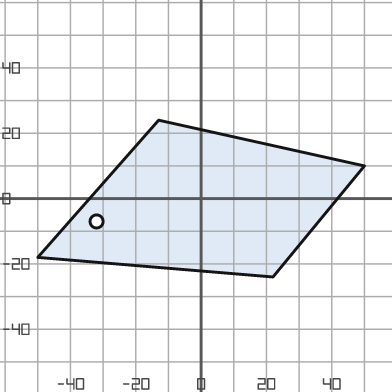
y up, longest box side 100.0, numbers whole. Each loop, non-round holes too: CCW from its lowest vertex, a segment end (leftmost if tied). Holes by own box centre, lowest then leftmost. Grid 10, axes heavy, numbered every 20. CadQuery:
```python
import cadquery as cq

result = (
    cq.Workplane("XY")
    .moveTo(22.0, -24.0)
    .lineTo(50.0, 10.0)
    .lineTo(-13.0, 24.0)
    .lineTo(-50.0, -18.0)
    .close()
    .moveTo(-32.0, -7.0)
    .circle(2.0)
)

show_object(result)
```